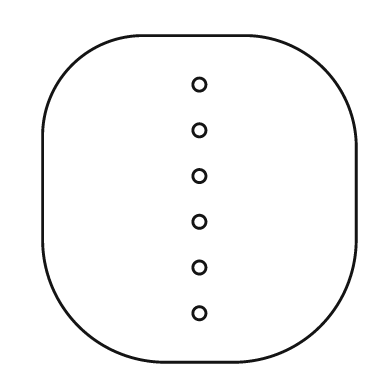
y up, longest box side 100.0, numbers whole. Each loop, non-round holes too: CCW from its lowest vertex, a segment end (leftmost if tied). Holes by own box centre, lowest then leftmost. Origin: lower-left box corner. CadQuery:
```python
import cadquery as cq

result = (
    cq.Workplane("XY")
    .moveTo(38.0, 0.0)
    .lineTo(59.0, 0.0)
    .threePointArc((85.0, 11.0), (96.0, 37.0))
    .lineTo(96.0, 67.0)
    .threePointArc((86.0, 90.0), (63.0, 100.0))
    .lineTo(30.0, 100.0)
    .threePointArc((9.0, 91.0), (0.0, 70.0))
    .lineTo(0.0, 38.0)
    .threePointArc((11.0, 11.0), (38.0, 0.0))
    .close()
    .moveTo(48.0, 15.0)
    .circle(2.0)
    .moveTo(48.0, 29.0)
    .circle(2.0)
    .moveTo(48.0, 43.0)
    .circle(2.0)
    .moveTo(48.0, 57.0)
    .circle(2.0)
    .moveTo(48.0, 71.0)
    .circle(2.0)
    .moveTo(48.0, 85.0)
    .circle(2.0)
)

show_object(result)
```